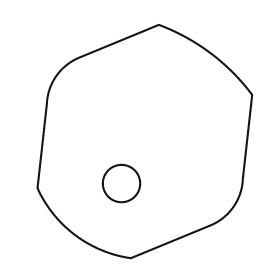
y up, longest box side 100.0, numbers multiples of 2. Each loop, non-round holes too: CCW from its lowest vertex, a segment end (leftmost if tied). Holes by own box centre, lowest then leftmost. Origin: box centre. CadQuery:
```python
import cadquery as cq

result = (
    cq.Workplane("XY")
    .moveTo(-6.0, -50.0)
    .lineTo(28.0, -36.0)
    .threePointArc((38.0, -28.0), (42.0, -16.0))
    .lineTo(46.0, 20.0)
    .threePointArc((28.0, 38.0), (6.0, 50.0))
    .lineTo(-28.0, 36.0)
    .threePointArc((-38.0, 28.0), (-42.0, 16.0))
    .lineTo(-46.0, -20.0)
    .threePointArc((-30.0, -40.0), (-6.0, -50.0))
    .close()
    .moveTo(-10.0, -18.0)
    .circle(8.0)
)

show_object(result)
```